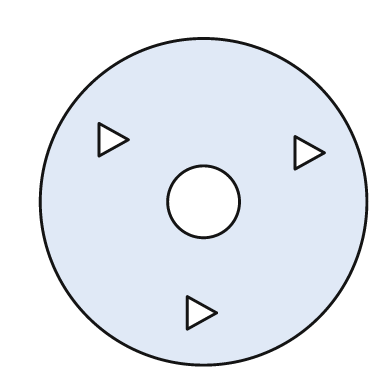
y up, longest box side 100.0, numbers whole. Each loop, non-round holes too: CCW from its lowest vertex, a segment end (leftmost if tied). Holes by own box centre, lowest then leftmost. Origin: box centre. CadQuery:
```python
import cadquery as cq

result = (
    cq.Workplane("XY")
    .moveTo(0.0, 0.0)
    .circle(50.0)
    .moveTo(-5.0, -39.0)
    .lineTo(4.0, -34.0)
    .lineTo(-5.0, -29.0)
    .close()
    .moveTo(0.0, 0.0)
    .circle(11.0)
    .moveTo(28.0, 10.0)
    .lineTo(37.0, 15.0)
    .lineTo(28.0, 20.0)
    .close()
    .moveTo(-32.0, 14.0)
    .lineTo(-23.0, 19.0)
    .lineTo(-32.0, 24.0)
    .close()
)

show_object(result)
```